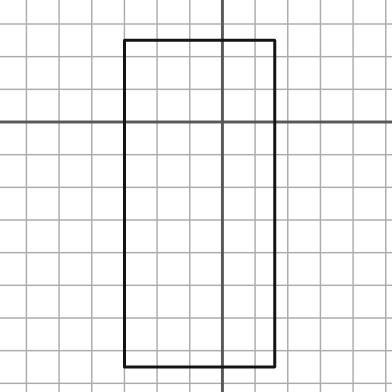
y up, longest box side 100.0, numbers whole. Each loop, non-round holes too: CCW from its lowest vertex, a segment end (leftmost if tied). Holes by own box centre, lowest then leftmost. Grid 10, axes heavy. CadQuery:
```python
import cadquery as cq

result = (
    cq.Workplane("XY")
    .moveTo(-30.0, -75.0)
    .lineTo(16.0, -75.0)
    .lineTo(16.0, 25.0)
    .lineTo(-30.0, 25.0)
    .close()
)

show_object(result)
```